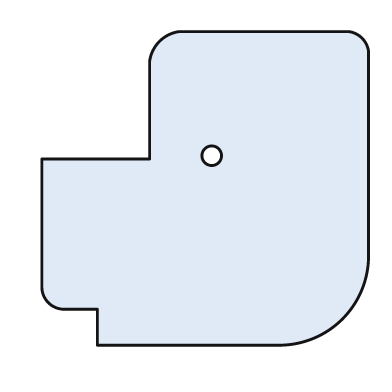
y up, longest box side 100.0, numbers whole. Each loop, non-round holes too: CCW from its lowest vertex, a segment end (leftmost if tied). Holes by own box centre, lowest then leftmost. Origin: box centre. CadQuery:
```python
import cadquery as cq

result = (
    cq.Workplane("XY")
    .moveTo(-33.0, -48.0)
    .lineTo(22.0, -48.0)
    .threePointArc((42.0, -40.0), (50.0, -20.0))
    .lineTo(50.0, 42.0)
    .threePointArc((48.0, 46.0), (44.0, 48.0))
    .lineTo(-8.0, 48.0)
    .threePointArc((-14.0, 45.0), (-17.0, 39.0))
    .lineTo(-17.0, 9.0)
    .lineTo(-50.0, 9.0)
    .lineTo(-50.0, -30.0)
    .threePointArc((-48.0, -35.0), (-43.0, -37.0))
    .lineTo(-33.0, -37.0)
    .close()
    .moveTo(2.0, 10.0)
    .circle(3.0)
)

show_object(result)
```